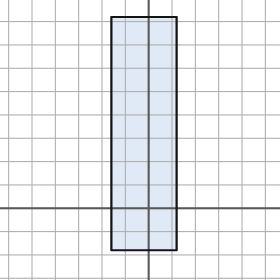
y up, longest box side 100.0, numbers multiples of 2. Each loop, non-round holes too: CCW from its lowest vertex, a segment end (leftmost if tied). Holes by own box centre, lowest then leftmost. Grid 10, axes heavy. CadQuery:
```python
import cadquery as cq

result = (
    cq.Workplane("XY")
    .moveTo(-16.0, -18.0)
    .lineTo(12.0, -18.0)
    .lineTo(12.0, 82.0)
    .lineTo(-16.0, 82.0)
    .close()
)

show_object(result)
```